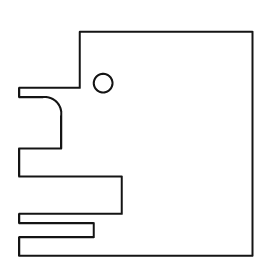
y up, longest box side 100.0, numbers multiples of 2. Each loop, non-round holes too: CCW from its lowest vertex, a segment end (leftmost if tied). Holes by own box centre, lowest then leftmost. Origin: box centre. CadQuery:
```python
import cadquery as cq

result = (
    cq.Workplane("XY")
    .moveTo(-50.0, -48.0)
    .lineTo(50.0, -48.0)
    .lineTo(50.0, 48.0)
    .lineTo(-24.0, 48.0)
    .lineTo(-24.0, 24.0)
    .lineTo(-50.0, 24.0)
    .lineTo(-50.0, 20.0)
    .lineTo(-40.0, 20.0)
    .threePointArc((-34.0, 18.0), (-32.0, 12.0))
    .lineTo(-32.0, -2.0)
    .lineTo(-50.0, -2.0)
    .lineTo(-50.0, -14.0)
    .lineTo(-6.0, -14.0)
    .lineTo(-6.0, -30.0)
    .lineTo(-50.0, -30.0)
    .lineTo(-50.0, -34.0)
    .lineTo(-18.0, -34.0)
    .lineTo(-18.0, -40.0)
    .lineTo(-50.0, -40.0)
    .close()
    .moveTo(-14.0, 26.0)
    .circle(4.0)
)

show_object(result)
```